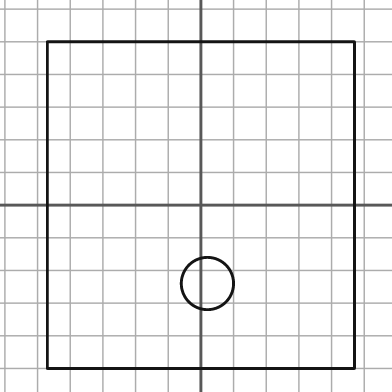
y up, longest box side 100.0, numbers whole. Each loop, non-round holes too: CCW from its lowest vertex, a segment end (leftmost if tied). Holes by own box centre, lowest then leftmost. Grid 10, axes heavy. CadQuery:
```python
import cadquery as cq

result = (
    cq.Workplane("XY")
    .moveTo(-47.0, -50.0)
    .lineTo(47.0, -50.0)
    .lineTo(47.0, 50.0)
    .lineTo(-47.0, 50.0)
    .close()
    .moveTo(2.0, -24.0)
    .circle(8.0)
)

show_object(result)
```